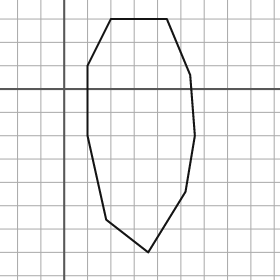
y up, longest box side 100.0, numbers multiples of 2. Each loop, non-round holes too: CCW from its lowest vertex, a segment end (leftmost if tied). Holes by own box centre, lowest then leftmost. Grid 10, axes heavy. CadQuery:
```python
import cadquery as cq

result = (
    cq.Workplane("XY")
    .moveTo(36.0, -70.0)
    .lineTo(52.0, -44.0)
    .lineTo(56.0, -20.0)
    .lineTo(54.0, 6.0)
    .lineTo(44.0, 30.0)
    .lineTo(20.0, 30.0)
    .lineTo(10.0, 10.0)
    .lineTo(10.0, -20.0)
    .lineTo(18.0, -56.0)
    .close()
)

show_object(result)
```